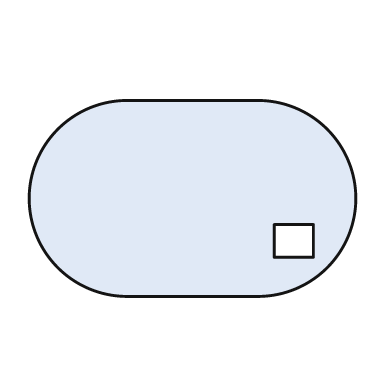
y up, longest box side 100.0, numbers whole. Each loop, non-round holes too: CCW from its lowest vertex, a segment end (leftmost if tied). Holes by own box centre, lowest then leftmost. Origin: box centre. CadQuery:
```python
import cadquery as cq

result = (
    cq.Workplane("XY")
    .moveTo(-20.0, -30.0)
    .lineTo(20.0, -30.0)
    .threePointArc((50.0, 0.0), (20.0, 30.0))
    .lineTo(-20.0, 30.0)
    .threePointArc((-50.0, 0.0), (-20.0, -30.0))
    .close()
    .moveTo(25.0, -18.0)
    .lineTo(37.0, -18.0)
    .lineTo(37.0, -8.0)
    .lineTo(25.0, -8.0)
    .close()
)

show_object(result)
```